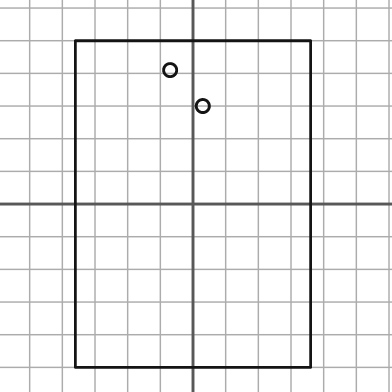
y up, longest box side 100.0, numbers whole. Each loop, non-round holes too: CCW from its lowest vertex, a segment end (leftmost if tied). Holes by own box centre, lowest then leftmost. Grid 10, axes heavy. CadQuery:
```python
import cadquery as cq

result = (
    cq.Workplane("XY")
    .moveTo(-36.0, -50.0)
    .lineTo(36.0, -50.0)
    .lineTo(36.0, 50.0)
    .lineTo(-36.0, 50.0)
    .close()
    .moveTo(3.0, 30.0)
    .circle(2.0)
    .moveTo(-7.0, 41.0)
    .circle(2.0)
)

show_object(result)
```